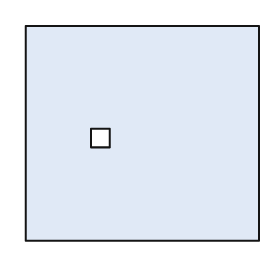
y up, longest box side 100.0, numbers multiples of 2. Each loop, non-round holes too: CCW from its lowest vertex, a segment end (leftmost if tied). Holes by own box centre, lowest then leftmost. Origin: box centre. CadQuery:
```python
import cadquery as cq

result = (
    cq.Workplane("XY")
    .moveTo(-50.0, -46.0)
    .lineTo(50.0, -46.0)
    .lineTo(50.0, 46.0)
    .lineTo(-50.0, 46.0)
    .close()
    .moveTo(-22.0, -6.0)
    .lineTo(-14.0, -6.0)
    .lineTo(-14.0, 2.0)
    .lineTo(-22.0, 2.0)
    .close()
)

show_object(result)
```